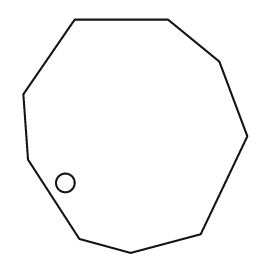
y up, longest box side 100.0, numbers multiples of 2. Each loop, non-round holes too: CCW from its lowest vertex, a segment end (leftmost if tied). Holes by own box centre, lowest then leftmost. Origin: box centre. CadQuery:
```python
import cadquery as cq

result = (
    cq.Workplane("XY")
    .moveTo(-2.0, -50.0)
    .lineTo(28.0, -42.0)
    .lineTo(48.0, 0.0)
    .lineTo(36.0, 32.0)
    .lineTo(14.0, 50.0)
    .lineTo(-26.0, 50.0)
    .lineTo(-48.0, 18.0)
    .lineTo(-46.0, -10.0)
    .lineTo(-24.0, -44.0)
    .close()
    .moveTo(-30.0, -20.0)
    .circle(4.0)
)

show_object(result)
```